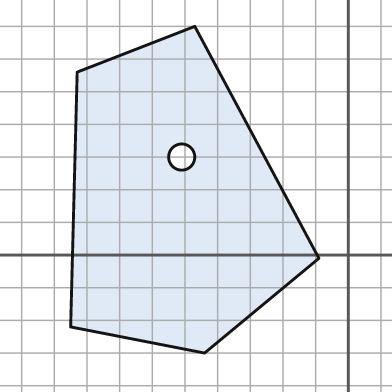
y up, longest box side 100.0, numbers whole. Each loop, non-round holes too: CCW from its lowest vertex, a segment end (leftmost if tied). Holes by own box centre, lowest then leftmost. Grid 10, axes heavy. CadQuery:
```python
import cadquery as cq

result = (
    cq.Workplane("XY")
    .moveTo(-44.0, -30.0)
    .lineTo(-9.0, -1.0)
    .lineTo(-47.0, 70.0)
    .lineTo(-83.0, 56.0)
    .lineTo(-85.0, -22.0)
    .close()
    .moveTo(-51.0, 30.0)
    .circle(4.0)
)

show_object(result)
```